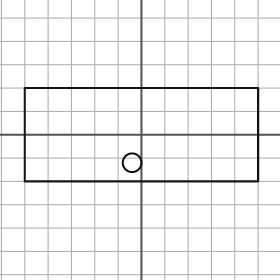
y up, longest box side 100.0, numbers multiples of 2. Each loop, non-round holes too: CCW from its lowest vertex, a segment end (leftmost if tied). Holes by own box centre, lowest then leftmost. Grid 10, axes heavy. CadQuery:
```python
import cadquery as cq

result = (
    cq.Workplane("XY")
    .moveTo(-50.0, -20.0)
    .lineTo(50.0, -20.0)
    .lineTo(50.0, 20.0)
    .lineTo(-50.0, 20.0)
    .close()
    .moveTo(-4.0, -12.0)
    .circle(4.0)
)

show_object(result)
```